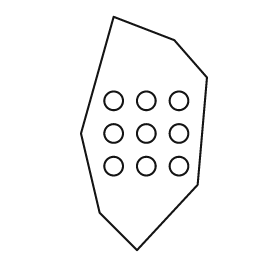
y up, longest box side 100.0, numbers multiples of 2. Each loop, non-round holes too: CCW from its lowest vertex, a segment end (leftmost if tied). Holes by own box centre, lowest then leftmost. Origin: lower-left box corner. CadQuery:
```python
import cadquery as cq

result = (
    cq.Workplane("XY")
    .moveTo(24.0, 0.0)
    .lineTo(50.0, 28.0)
    .lineTo(54.0, 74.0)
    .lineTo(40.0, 90.0)
    .lineTo(14.0, 100.0)
    .lineTo(0.0, 50.0)
    .lineTo(8.0, 16.0)
    .close()
    .moveTo(14.0, 36.0)
    .circle(4.0)
    .moveTo(28.0, 36.0)
    .circle(4.0)
    .moveTo(42.0, 36.0)
    .circle(4.0)
    .moveTo(14.0, 50.0)
    .circle(4.0)
    .moveTo(28.0, 50.0)
    .circle(4.0)
    .moveTo(42.0, 50.0)
    .circle(4.0)
    .moveTo(14.0, 64.0)
    .circle(4.0)
    .moveTo(28.0, 64.0)
    .circle(4.0)
    .moveTo(42.0, 64.0)
    .circle(4.0)
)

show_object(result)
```